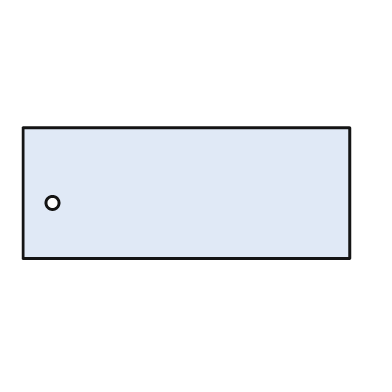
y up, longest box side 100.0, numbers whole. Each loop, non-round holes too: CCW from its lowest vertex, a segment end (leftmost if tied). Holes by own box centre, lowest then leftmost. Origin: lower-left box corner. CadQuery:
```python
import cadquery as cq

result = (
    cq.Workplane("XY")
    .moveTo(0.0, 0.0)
    .lineTo(100.0, 0.0)
    .lineTo(100.0, 40.0)
    .lineTo(0.0, 40.0)
    .close()
    .moveTo(9.0, 17.0)
    .circle(2.0)
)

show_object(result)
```